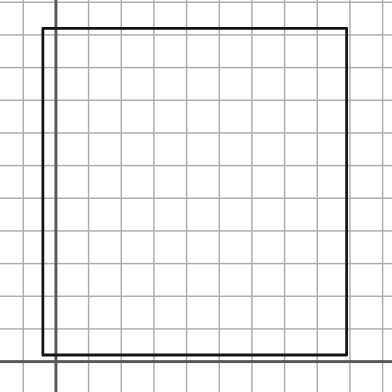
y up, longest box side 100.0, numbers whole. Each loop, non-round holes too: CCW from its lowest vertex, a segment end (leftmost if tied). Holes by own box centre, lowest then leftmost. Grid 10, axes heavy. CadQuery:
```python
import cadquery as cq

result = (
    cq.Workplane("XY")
    .moveTo(-4.0, 2.0)
    .lineTo(89.0, 2.0)
    .lineTo(89.0, 102.0)
    .lineTo(-4.0, 102.0)
    .close()
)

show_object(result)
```